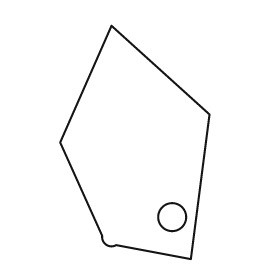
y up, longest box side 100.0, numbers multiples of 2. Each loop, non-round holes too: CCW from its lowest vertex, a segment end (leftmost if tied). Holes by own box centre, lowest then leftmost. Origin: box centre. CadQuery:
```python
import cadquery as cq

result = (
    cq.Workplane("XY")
    .moveTo(24.0, -50.0)
    .lineTo(32.0, 12.0)
    .lineTo(-10.0, 50.0)
    .lineTo(-32.0, 0.0)
    .lineTo(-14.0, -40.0)
    .threePointArc((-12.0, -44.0), (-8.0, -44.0))
    .close()
    .moveTo(16.0, -32.0)
    .circle(6.0)
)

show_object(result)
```